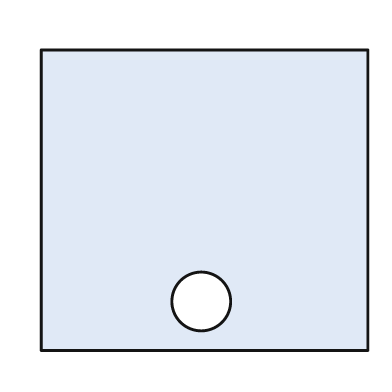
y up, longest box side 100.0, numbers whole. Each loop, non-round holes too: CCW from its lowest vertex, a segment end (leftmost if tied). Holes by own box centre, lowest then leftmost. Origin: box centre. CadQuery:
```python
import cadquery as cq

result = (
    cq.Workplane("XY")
    .moveTo(-50.0, -46.0)
    .lineTo(50.0, -46.0)
    .lineTo(50.0, 46.0)
    .lineTo(-50.0, 46.0)
    .close()
    .moveTo(-1.0, -31.0)
    .circle(9.0)
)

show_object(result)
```